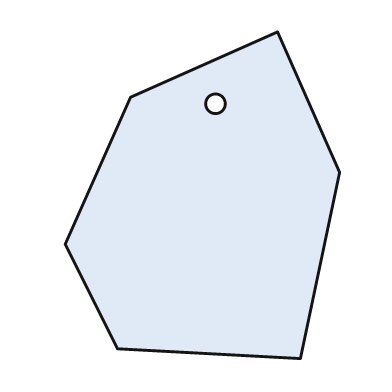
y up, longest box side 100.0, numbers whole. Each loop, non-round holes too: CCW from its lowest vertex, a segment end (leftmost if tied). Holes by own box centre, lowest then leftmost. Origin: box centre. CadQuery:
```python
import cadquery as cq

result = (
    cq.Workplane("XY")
    .moveTo(30.0, -50.0)
    .lineTo(42.0, 7.0)
    .lineTo(23.0, 50.0)
    .lineTo(-22.0, 30.0)
    .lineTo(-42.0, -15.0)
    .lineTo(-26.0, -47.0)
    .close()
    .moveTo(4.0, 28.0)
    .circle(3.0)
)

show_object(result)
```